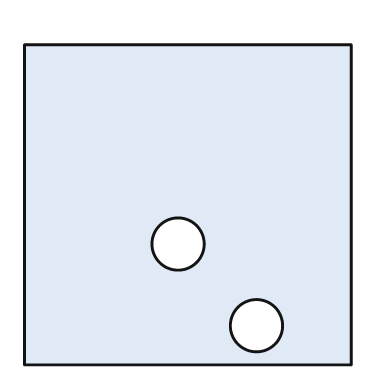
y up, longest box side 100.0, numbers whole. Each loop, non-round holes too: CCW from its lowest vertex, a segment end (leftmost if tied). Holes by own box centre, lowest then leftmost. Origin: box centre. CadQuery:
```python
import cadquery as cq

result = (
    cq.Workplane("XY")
    .moveTo(-50.0, -49.0)
    .lineTo(50.0, -49.0)
    .lineTo(50.0, 49.0)
    .lineTo(-50.0, 49.0)
    .close()
    .moveTo(21.0, -37.0)
    .circle(8.0)
    .moveTo(-3.0, -12.0)
    .circle(8.0)
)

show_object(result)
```